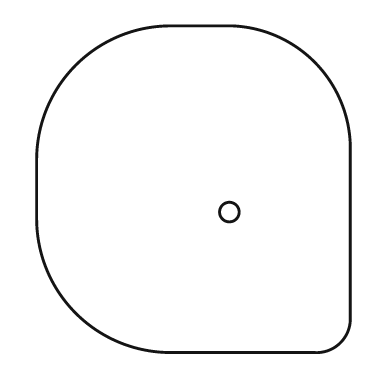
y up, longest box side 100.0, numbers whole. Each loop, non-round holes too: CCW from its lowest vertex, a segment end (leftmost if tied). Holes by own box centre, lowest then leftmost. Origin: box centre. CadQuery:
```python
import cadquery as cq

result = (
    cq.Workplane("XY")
    .moveTo(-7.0, -50.0)
    .lineTo(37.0, -50.0)
    .threePointArc((45.0, -47.0), (48.0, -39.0))
    .lineTo(48.0, 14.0)
    .threePointArc((37.0, 39.0), (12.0, 50.0))
    .lineTo(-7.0, 50.0)
    .threePointArc((-36.0, 38.0), (-48.0, 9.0))
    .lineTo(-48.0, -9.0)
    .threePointArc((-36.0, -38.0), (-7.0, -50.0))
    .close()
    .moveTo(11.0, -7.0)
    .circle(3.0)
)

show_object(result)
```